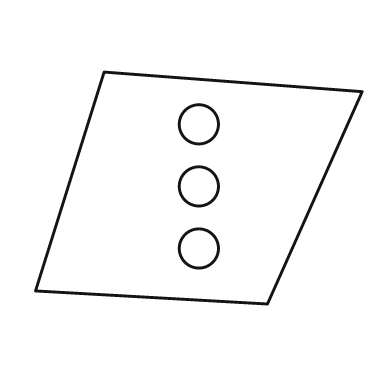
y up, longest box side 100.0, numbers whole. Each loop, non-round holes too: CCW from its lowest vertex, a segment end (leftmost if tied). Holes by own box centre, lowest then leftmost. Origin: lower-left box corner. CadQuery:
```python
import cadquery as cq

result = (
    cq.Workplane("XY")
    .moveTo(71.0, 0.0)
    .lineTo(100.0, 65.0)
    .lineTo(21.0, 71.0)
    .lineTo(0.0, 4.0)
    .close()
    .moveTo(50.0, 17.0)
    .circle(6.0)
    .moveTo(50.0, 36.0)
    .circle(6.0)
    .moveTo(50.0, 55.0)
    .circle(6.0)
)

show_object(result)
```